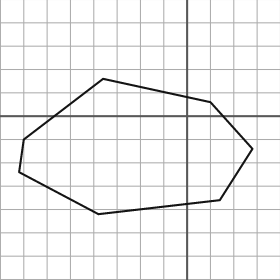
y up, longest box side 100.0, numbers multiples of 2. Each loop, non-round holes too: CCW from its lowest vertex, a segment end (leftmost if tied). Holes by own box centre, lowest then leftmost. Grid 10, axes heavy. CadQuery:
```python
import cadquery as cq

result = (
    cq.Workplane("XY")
    .moveTo(-38.0, -42.0)
    .lineTo(14.0, -36.0)
    .lineTo(28.0, -14.0)
    .lineTo(10.0, 6.0)
    .lineTo(-36.0, 16.0)
    .lineTo(-70.0, -10.0)
    .lineTo(-72.0, -24.0)
    .close()
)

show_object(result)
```